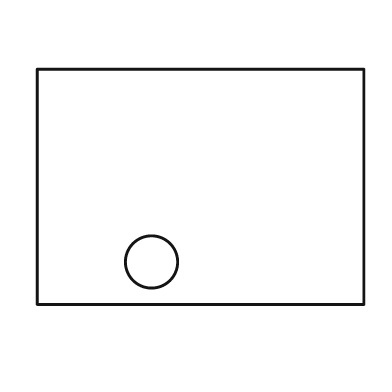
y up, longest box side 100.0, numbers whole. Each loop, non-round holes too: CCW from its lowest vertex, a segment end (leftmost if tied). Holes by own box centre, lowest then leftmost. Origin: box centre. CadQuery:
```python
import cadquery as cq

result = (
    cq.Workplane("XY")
    .moveTo(-50.0, -36.0)
    .lineTo(50.0, -36.0)
    .lineTo(50.0, 36.0)
    .lineTo(-50.0, 36.0)
    .close()
    .moveTo(-15.0, -23.0)
    .circle(8.0)
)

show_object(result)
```